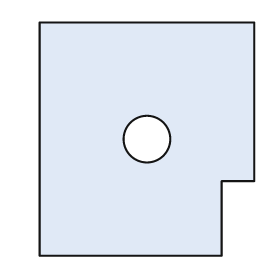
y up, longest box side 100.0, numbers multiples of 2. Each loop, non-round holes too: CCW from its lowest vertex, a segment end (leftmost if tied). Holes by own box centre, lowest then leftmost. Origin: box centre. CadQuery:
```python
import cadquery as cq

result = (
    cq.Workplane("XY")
    .moveTo(-46.0, -50.0)
    .lineTo(32.0, -50.0)
    .lineTo(32.0, -18.0)
    .lineTo(46.0, -18.0)
    .lineTo(46.0, 50.0)
    .lineTo(-46.0, 50.0)
    .close()
    .moveTo(0.0, 0.0)
    .circle(10.0)
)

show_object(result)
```